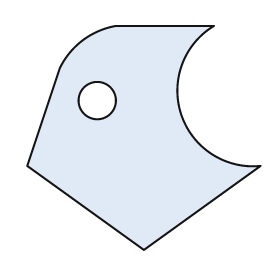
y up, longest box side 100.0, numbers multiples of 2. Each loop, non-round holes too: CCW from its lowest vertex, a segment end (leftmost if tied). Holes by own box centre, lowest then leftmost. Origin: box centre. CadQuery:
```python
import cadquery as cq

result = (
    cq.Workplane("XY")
    .moveTo(0.0, -48.0)
    .lineTo(50.0, -12.0)
    .threePointArc((16.0, 10.0), (30.0, 48.0))
    .lineTo(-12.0, 48.0)
    .threePointArc((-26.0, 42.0), (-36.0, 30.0))
    .lineTo(-50.0, -12.0)
    .close()
    .moveTo(-20.0, 16.0)
    .circle(8.0)
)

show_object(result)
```